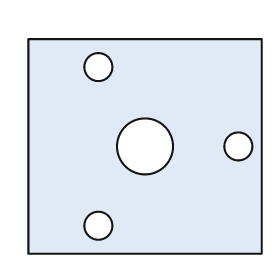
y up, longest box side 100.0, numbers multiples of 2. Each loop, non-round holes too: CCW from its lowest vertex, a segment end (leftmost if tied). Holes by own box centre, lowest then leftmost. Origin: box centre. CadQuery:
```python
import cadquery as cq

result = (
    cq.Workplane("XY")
    .moveTo(-50.0, -46.0)
    .lineTo(50.0, -46.0)
    .lineTo(50.0, 46.0)
    .lineTo(-50.0, 46.0)
    .close()
    .moveTo(-20.0, -34.0)
    .circle(6.0)
    .moveTo(0.0, 0.0)
    .circle(12.0)
    .moveTo(40.0, 0.0)
    .circle(6.0)
    .moveTo(-20.0, 34.0)
    .circle(6.0)
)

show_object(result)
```